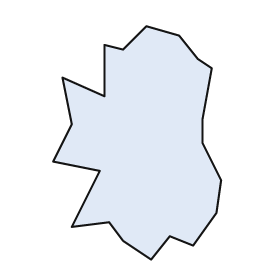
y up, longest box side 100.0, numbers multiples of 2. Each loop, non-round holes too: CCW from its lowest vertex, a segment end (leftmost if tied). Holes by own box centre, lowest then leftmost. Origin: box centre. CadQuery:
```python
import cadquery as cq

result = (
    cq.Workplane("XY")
    .moveTo(6.0, -50.0)
    .lineTo(14.0, -40.0)
    .lineTo(24.0, -44.0)
    .lineTo(34.0, -30.0)
    .lineTo(36.0, -16.0)
    .lineTo(28.0, 0.0)
    .lineTo(28.0, 10.0)
    .lineTo(32.0, 32.0)
    .lineTo(26.0, 36.0)
    .lineTo(18.0, 46.0)
    .lineTo(4.0, 50.0)
    .lineTo(-6.0, 40.0)
    .lineTo(-14.0, 42.0)
    .lineTo(-14.0, 20.0)
    .lineTo(-32.0, 28.0)
    .lineTo(-28.0, 8.0)
    .lineTo(-36.0, -8.0)
    .lineTo(-16.0, -12.0)
    .lineTo(-28.0, -36.0)
    .lineTo(-12.0, -34.0)
    .lineTo(-6.0, -42.0)
    .close()
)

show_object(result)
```